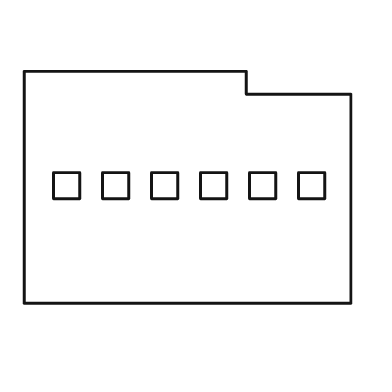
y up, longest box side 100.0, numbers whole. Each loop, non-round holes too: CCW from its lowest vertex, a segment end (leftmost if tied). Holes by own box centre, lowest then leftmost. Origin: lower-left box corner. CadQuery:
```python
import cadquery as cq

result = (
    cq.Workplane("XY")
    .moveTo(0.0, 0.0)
    .lineTo(100.0, 0.0)
    .lineTo(100.0, 64.0)
    .lineTo(68.0, 64.0)
    .lineTo(68.0, 71.0)
    .lineTo(0.0, 71.0)
    .close()
    .moveTo(9.0, 32.0)
    .lineTo(17.0, 32.0)
    .lineTo(17.0, 40.0)
    .lineTo(9.0, 40.0)
    .close()
    .moveTo(24.0, 32.0)
    .lineTo(32.0, 32.0)
    .lineTo(32.0, 40.0)
    .lineTo(24.0, 40.0)
    .close()
    .moveTo(39.0, 32.0)
    .lineTo(47.0, 32.0)
    .lineTo(47.0, 40.0)
    .lineTo(39.0, 40.0)
    .close()
    .moveTo(54.0, 32.0)
    .lineTo(62.0, 32.0)
    .lineTo(62.0, 40.0)
    .lineTo(54.0, 40.0)
    .close()
    .moveTo(69.0, 32.0)
    .lineTo(77.0, 32.0)
    .lineTo(77.0, 40.0)
    .lineTo(69.0, 40.0)
    .close()
    .moveTo(84.0, 32.0)
    .lineTo(92.0, 32.0)
    .lineTo(92.0, 40.0)
    .lineTo(84.0, 40.0)
    .close()
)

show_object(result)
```